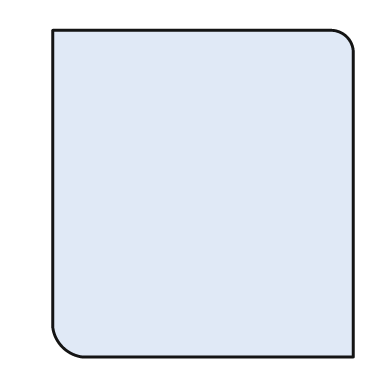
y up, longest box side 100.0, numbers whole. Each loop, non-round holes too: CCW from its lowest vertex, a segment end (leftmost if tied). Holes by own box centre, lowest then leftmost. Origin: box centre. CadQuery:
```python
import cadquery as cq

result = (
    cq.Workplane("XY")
    .moveTo(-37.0, -50.0)
    .lineTo(46.0, -50.0)
    .lineTo(46.0, 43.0)
    .threePointArc((44.0, 48.0), (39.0, 50.0))
    .lineTo(-46.0, 50.0)
    .lineTo(-46.0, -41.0)
    .threePointArc((-43.0, -47.0), (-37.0, -50.0))
    .close()
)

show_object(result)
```